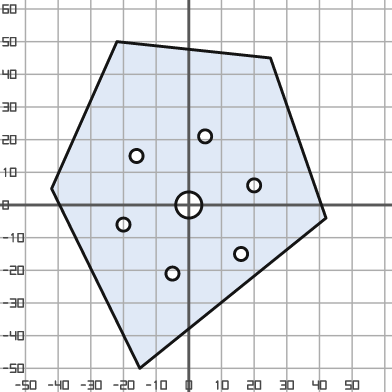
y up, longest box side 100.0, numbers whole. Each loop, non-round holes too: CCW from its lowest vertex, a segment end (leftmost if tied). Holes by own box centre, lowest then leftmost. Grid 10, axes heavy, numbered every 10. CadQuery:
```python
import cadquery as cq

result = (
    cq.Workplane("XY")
    .moveTo(-15.0, -50.0)
    .lineTo(42.0, -4.0)
    .lineTo(25.0, 45.0)
    .lineTo(-22.0, 50.0)
    .lineTo(-42.0, 5.0)
    .close()
    .moveTo(-5.0, -21.0)
    .circle(2.0)
    .moveTo(16.0, -15.0)
    .circle(2.0)
    .moveTo(-20.0, -6.0)
    .circle(2.0)
    .moveTo(0.0, 0.0)
    .circle(4.0)
    .moveTo(20.0, 6.0)
    .circle(2.0)
    .moveTo(-16.0, 15.0)
    .circle(2.0)
    .moveTo(5.0, 21.0)
    .circle(2.0)
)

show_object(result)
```